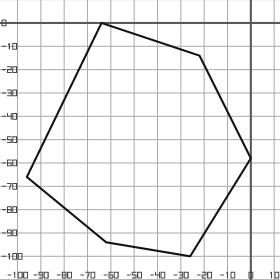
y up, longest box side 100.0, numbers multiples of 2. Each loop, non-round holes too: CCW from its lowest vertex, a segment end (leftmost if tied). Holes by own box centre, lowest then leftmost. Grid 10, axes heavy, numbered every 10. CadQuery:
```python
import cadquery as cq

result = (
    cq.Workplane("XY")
    .moveTo(-26.0, -100.0)
    .lineTo(0.0, -58.0)
    .lineTo(-22.0, -14.0)
    .lineTo(-64.0, 0.0)
    .lineTo(-96.0, -66.0)
    .lineTo(-62.0, -94.0)
    .close()
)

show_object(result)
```